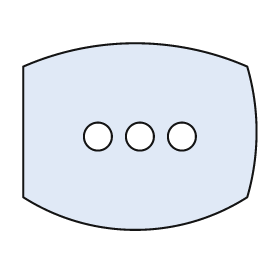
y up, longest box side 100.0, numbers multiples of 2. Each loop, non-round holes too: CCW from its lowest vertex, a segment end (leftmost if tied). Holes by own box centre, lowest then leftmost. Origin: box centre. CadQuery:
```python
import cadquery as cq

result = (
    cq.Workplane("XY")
    .moveTo(-50.0, -26.0)
    .threePointArc((-2.0, -40.0), (46.0, -26.0))
    .threePointArc((50.0, 2.0), (46.0, 30.0))
    .threePointArc((-2.0, 40.0), (-50.0, 30.0))
    .close()
    .moveTo(-18.0, 0.0)
    .circle(6.0)
    .moveTo(0.0, 0.0)
    .circle(6.0)
    .moveTo(18.0, 0.0)
    .circle(6.0)
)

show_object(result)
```